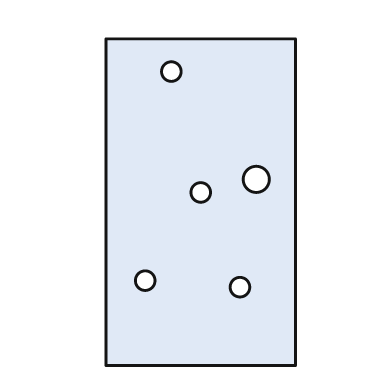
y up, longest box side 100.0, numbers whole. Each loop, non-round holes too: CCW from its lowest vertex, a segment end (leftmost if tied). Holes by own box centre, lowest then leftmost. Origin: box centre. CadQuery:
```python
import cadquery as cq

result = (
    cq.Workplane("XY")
    .moveTo(-29.0, -50.0)
    .lineTo(29.0, -50.0)
    .lineTo(29.0, 50.0)
    .lineTo(-29.0, 50.0)
    .close()
    .moveTo(12.0, -26.0)
    .circle(3.0)
    .moveTo(-17.0, -24.0)
    .circle(3.0)
    .moveTo(0.0, 3.0)
    .circle(3.0)
    .moveTo(17.0, 7.0)
    .circle(4.0)
    .moveTo(-9.0, 40.0)
    .circle(3.0)
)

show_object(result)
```